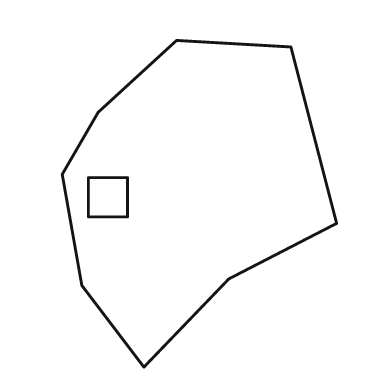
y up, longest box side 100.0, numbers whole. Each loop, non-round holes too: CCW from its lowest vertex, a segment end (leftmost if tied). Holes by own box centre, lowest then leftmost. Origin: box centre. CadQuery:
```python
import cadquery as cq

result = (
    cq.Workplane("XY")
    .moveTo(-17.0, -50.0)
    .lineTo(9.0, -23.0)
    .lineTo(42.0, -6.0)
    .lineTo(28.0, 48.0)
    .lineTo(-7.0, 50.0)
    .lineTo(-31.0, 28.0)
    .lineTo(-42.0, 9.0)
    .lineTo(-36.0, -25.0)
    .close()
    .moveTo(-34.0, -4.0)
    .lineTo(-22.0, -4.0)
    .lineTo(-22.0, 8.0)
    .lineTo(-34.0, 8.0)
    .close()
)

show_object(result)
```